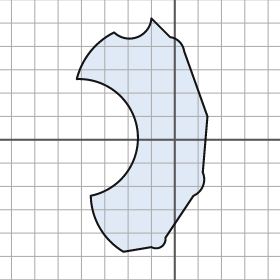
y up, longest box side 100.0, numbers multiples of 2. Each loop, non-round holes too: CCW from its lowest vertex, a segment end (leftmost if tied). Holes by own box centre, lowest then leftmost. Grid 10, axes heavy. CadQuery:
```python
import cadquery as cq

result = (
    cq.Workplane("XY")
    .moveTo(-22.0, -48.0)
    .lineTo(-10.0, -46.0)
    .threePointArc((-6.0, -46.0), (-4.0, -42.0))
    .lineTo(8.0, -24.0)
    .threePointArc((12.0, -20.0), (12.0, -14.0))
    .lineTo(14.0, 10.0)
    .lineTo(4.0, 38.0)
    .threePointArc((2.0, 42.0), (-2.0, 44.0))
    .lineTo(-10.0, 52.0)
    .threePointArc((-16.0, 44.0), (-26.0, 46.0))
    .threePointArc((-36.0, 38.0), (-42.0, 26.0))
    .threePointArc((-16.0, 4.0), (-36.0, -24.0))
    .threePointArc((-32.0, -38.0), (-22.0, -48.0))
    .close()
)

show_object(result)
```